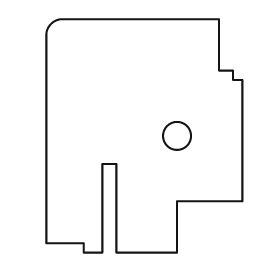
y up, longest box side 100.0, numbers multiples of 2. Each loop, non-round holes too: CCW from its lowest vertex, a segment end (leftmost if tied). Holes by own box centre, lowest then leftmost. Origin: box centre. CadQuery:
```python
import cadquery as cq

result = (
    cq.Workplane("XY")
    .moveTo(-26.0, -50.0)
    .lineTo(-18.0, -50.0)
    .lineTo(-18.0, -12.0)
    .lineTo(-12.0, -12.0)
    .lineTo(-12.0, -50.0)
    .lineTo(14.0, -50.0)
    .lineTo(14.0, -28.0)
    .lineTo(42.0, -28.0)
    .lineTo(42.0, 24.0)
    .lineTo(38.0, 24.0)
    .lineTo(38.0, 28.0)
    .lineTo(32.0, 28.0)
    .lineTo(32.0, 50.0)
    .lineTo(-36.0, 50.0)
    .threePointArc((-40.0, 48.0), (-42.0, 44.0))
    .lineTo(-42.0, -46.0)
    .lineTo(-26.0, -46.0)
    .close()
    .moveTo(14.0, 0.0)
    .circle(6.0)
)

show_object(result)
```